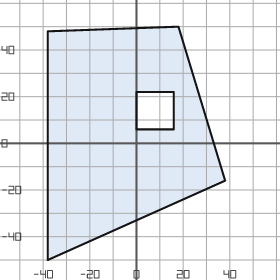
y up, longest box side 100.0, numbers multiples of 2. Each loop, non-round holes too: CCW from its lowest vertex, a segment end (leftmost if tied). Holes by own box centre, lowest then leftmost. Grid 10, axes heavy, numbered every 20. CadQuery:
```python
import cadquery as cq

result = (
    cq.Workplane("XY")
    .moveTo(-38.0, -50.0)
    .lineTo(38.0, -16.0)
    .lineTo(18.0, 50.0)
    .lineTo(-38.0, 48.0)
    .close()
    .moveTo(0.0, 6.0)
    .lineTo(16.0, 6.0)
    .lineTo(16.0, 22.0)
    .lineTo(0.0, 22.0)
    .close()
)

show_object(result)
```